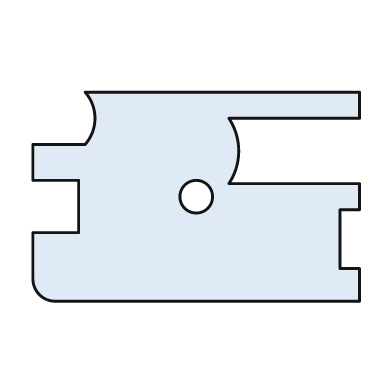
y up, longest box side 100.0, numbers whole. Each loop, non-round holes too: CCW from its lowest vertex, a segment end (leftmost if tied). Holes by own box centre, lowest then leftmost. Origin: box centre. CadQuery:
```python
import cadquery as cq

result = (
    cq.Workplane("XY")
    .moveTo(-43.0, -32.0)
    .lineTo(50.0, -32.0)
    .lineTo(50.0, -22.0)
    .lineTo(44.0, -22.0)
    .lineTo(44.0, -4.0)
    .lineTo(50.0, -4.0)
    .lineTo(50.0, 4.0)
    .lineTo(10.0, 4.0)
    .threePointArc((13.0, 14.0), (10.0, 24.0))
    .lineTo(50.0, 24.0)
    .lineTo(50.0, 32.0)
    .lineTo(-34.0, 32.0)
    .threePointArc((-31.0, 24.0), (-34.0, 16.0))
    .lineTo(-50.0, 16.0)
    .lineTo(-50.0, 5.0)
    .lineTo(-36.0, 5.0)
    .lineTo(-36.0, -11.0)
    .lineTo(-50.0, -11.0)
    .lineTo(-50.0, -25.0)
    .threePointArc((-48.0, -30.0), (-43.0, -32.0))
    .close()
    .moveTo(0.0, 0.0)
    .circle(5.0)
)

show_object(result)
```